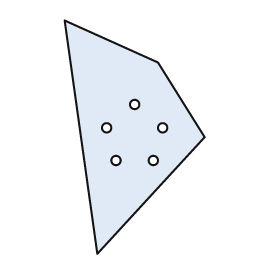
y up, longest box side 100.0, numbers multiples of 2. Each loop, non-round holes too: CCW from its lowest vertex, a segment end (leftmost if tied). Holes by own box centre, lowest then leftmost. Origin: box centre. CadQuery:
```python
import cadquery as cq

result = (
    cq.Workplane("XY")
    .moveTo(-16.0, -50.0)
    .lineTo(30.0, 0.0)
    .lineTo(10.0, 32.0)
    .lineTo(-30.0, 50.0)
    .close()
    .moveTo(-8.0, -10.0)
    .circle(2.0)
    .moveTo(8.0, -10.0)
    .circle(2.0)
    .moveTo(-12.0, 4.0)
    .circle(2.0)
    .moveTo(12.0, 4.0)
    .circle(2.0)
    .moveTo(0.0, 14.0)
    .circle(2.0)
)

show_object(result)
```